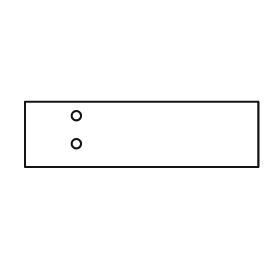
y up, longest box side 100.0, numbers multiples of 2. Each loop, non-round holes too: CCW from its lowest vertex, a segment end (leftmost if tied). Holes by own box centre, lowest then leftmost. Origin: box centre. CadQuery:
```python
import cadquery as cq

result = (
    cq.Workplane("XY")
    .moveTo(-50.0, -14.0)
    .lineTo(50.0, -14.0)
    .lineTo(50.0, 14.0)
    .lineTo(-50.0, 14.0)
    .close()
    .moveTo(-28.0, -4.0)
    .circle(2.0)
    .moveTo(-28.0, 8.0)
    .circle(2.0)
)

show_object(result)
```